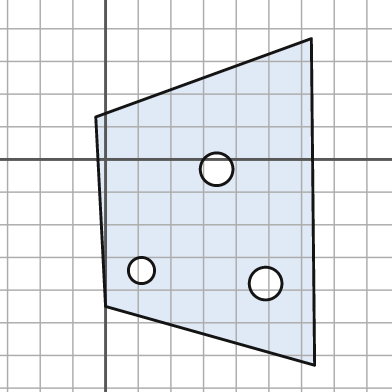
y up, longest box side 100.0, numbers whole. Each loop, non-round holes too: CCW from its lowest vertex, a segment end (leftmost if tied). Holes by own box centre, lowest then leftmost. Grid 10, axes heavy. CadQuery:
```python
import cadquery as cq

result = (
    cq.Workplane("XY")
    .moveTo(64.0, -63.0)
    .lineTo(63.0, 37.0)
    .lineTo(-3.0, 13.0)
    .lineTo(0.0, -45.0)
    .close()
    .moveTo(49.0, -38.0)
    .circle(5.0)
    .moveTo(11.0, -34.0)
    .circle(4.0)
    .moveTo(34.0, -3.0)
    .circle(5.0)
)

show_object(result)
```